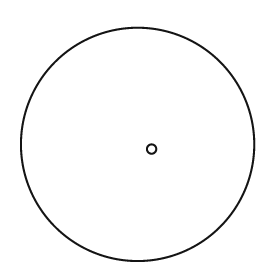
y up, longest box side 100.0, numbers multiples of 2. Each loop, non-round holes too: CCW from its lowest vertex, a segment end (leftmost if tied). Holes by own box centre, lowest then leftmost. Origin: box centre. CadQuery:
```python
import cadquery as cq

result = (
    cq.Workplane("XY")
    .moveTo(0.0, 0.0)
    .circle(50.0)
    .moveTo(6.0, -2.0)
    .circle(2.0)
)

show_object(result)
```